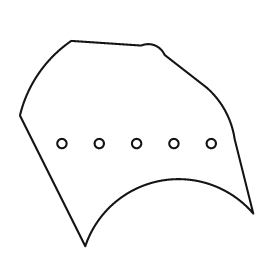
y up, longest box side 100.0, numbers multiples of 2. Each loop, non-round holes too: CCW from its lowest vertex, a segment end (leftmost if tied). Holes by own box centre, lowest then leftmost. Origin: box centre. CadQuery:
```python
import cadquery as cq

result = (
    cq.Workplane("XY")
    .moveTo(-22.0, -44.0)
    .threePointArc((10.0, -16.0), (50.0, -30.0))
    .lineTo(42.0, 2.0)
    .threePointArc((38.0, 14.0), (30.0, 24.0))
    .lineTo(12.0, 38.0)
    .threePointArc((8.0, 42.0), (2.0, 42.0))
    .lineTo(-28.0, 44.0)
    .threePointArc((-42.0, 30.0), (-50.0, 12.0))
    .close()
    .moveTo(-32.0, 0.0)
    .circle(2.0)
    .moveTo(-16.0, 0.0)
    .circle(2.0)
    .moveTo(0.0, 0.0)
    .circle(2.0)
    .moveTo(16.0, 0.0)
    .circle(2.0)
    .moveTo(32.0, 0.0)
    .circle(2.0)
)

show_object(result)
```